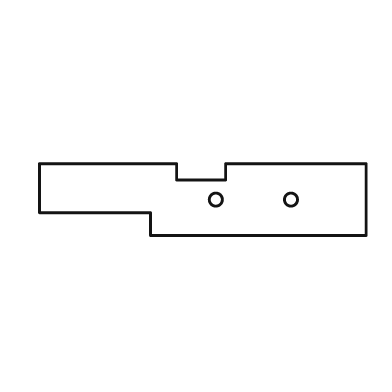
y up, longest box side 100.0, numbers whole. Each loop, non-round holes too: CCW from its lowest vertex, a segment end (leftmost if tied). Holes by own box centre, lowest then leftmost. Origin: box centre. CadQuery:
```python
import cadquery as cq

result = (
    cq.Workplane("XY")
    .moveTo(-16.0, -11.0)
    .lineTo(50.0, -11.0)
    .lineTo(50.0, 11.0)
    .lineTo(7.0, 11.0)
    .lineTo(7.0, 6.0)
    .lineTo(-8.0, 6.0)
    .lineTo(-8.0, 11.0)
    .lineTo(-50.0, 11.0)
    .lineTo(-50.0, -4.0)
    .lineTo(-16.0, -4.0)
    .close()
    .moveTo(4.0, 0.0)
    .circle(2.0)
    .moveTo(27.0, 0.0)
    .circle(2.0)
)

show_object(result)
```